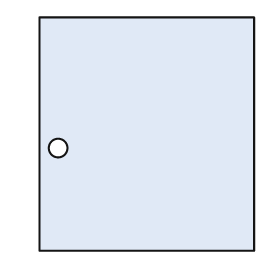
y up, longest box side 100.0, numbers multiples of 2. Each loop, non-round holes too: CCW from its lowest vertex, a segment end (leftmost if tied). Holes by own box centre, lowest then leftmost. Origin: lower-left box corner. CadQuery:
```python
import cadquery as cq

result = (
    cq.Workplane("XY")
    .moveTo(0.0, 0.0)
    .lineTo(92.0, 0.0)
    .lineTo(92.0, 100.0)
    .lineTo(0.0, 100.0)
    .close()
    .moveTo(8.0, 44.0)
    .circle(4.0)
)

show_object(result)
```